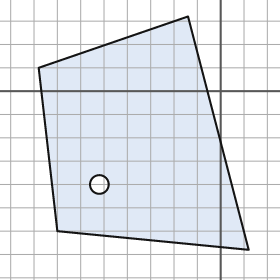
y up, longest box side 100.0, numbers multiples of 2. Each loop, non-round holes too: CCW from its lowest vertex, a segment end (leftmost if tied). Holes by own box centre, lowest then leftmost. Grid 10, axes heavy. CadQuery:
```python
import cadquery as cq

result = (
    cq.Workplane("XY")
    .moveTo(12.0, -68.0)
    .lineTo(-14.0, 32.0)
    .lineTo(-78.0, 10.0)
    .lineTo(-70.0, -60.0)
    .close()
    .moveTo(-52.0, -40.0)
    .circle(4.0)
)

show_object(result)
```